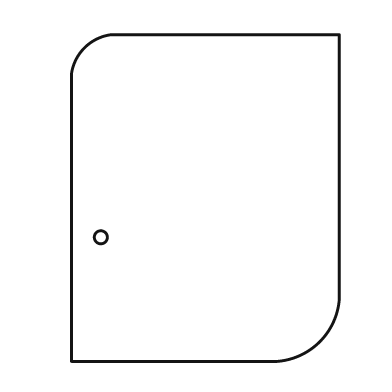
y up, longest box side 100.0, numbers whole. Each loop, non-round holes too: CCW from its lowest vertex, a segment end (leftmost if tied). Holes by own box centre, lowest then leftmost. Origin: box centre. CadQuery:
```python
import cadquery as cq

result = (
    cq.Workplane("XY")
    .moveTo(-41.0, -50.0)
    .lineTo(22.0, -50.0)
    .threePointArc((35.0, -44.0), (41.0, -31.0))
    .lineTo(41.0, 50.0)
    .lineTo(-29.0, 50.0)
    .threePointArc((-37.0, 46.0), (-41.0, 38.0))
    .close()
    .moveTo(-32.0, -12.0)
    .circle(2.0)
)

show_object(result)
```